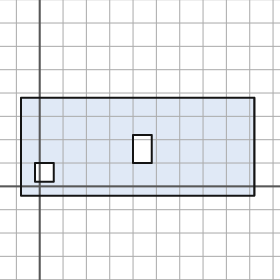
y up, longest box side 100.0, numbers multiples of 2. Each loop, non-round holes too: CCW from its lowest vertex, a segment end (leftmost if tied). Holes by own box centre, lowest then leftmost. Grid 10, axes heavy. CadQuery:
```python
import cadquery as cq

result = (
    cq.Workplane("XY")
    .moveTo(-8.0, -4.0)
    .lineTo(92.0, -4.0)
    .lineTo(92.0, 38.0)
    .lineTo(-8.0, 38.0)
    .close()
    .moveTo(-2.0, 2.0)
    .lineTo(6.0, 2.0)
    .lineTo(6.0, 10.0)
    .lineTo(-2.0, 10.0)
    .close()
    .moveTo(40.0, 10.0)
    .lineTo(48.0, 10.0)
    .lineTo(48.0, 22.0)
    .lineTo(40.0, 22.0)
    .close()
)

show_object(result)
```